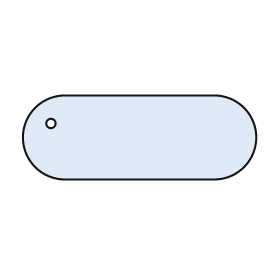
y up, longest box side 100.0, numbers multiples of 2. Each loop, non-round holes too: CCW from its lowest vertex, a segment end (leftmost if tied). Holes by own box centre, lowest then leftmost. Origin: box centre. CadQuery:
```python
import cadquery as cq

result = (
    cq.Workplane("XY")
    .moveTo(-32.0, -18.0)
    .lineTo(32.0, -18.0)
    .threePointArc((50.0, 0.0), (32.0, 18.0))
    .lineTo(-32.0, 18.0)
    .threePointArc((-50.0, 0.0), (-32.0, -18.0))
    .close()
    .moveTo(-38.0, 6.0)
    .circle(2.0)
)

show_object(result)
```